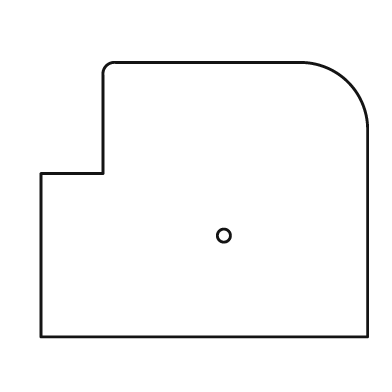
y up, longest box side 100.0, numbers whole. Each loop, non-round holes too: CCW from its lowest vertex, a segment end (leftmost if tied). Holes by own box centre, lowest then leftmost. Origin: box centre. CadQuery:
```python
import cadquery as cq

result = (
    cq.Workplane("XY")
    .moveTo(-50.0, -42.0)
    .lineTo(50.0, -42.0)
    .lineTo(50.0, 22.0)
    .threePointArc((44.0, 36.0), (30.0, 42.0))
    .lineTo(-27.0, 42.0)
    .threePointArc((-30.0, 41.0), (-31.0, 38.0))
    .lineTo(-31.0, 8.0)
    .lineTo(-50.0, 8.0)
    .close()
    .moveTo(6.0, -11.0)
    .circle(2.0)
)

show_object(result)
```